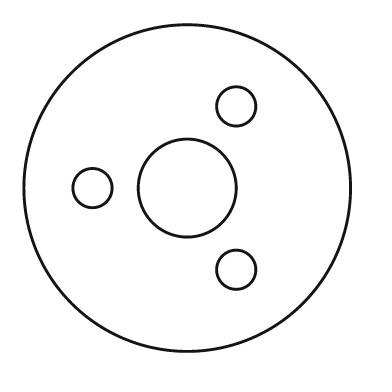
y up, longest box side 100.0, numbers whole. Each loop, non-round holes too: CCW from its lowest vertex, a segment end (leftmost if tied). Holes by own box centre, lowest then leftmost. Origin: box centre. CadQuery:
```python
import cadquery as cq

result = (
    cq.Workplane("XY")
    .moveTo(0.0, 0.0)
    .circle(50.0)
    .moveTo(15.0, -25.0)
    .circle(6.0)
    .moveTo(-29.0, 0.0)
    .circle(6.0)
    .moveTo(0.0, 0.0)
    .circle(15.0)
    .moveTo(15.0, 25.0)
    .circle(6.0)
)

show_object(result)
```